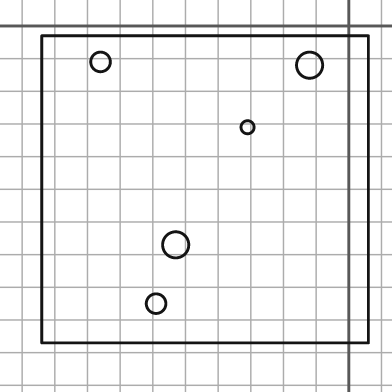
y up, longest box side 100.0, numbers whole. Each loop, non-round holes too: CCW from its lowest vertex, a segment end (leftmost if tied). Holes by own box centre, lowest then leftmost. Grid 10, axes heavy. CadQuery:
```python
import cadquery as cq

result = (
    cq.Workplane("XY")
    .moveTo(-94.0, -97.0)
    .lineTo(6.0, -97.0)
    .lineTo(6.0, -3.0)
    .lineTo(-94.0, -3.0)
    .close()
    .moveTo(-59.0, -85.0)
    .circle(3.0)
    .moveTo(-53.0, -67.0)
    .circle(4.0)
    .moveTo(-31.0, -31.0)
    .circle(2.0)
    .moveTo(-12.0, -12.0)
    .circle(4.0)
    .moveTo(-76.0, -11.0)
    .circle(3.0)
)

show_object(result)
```